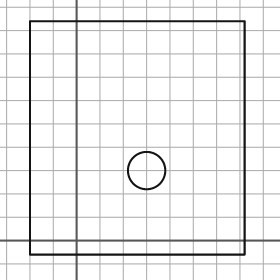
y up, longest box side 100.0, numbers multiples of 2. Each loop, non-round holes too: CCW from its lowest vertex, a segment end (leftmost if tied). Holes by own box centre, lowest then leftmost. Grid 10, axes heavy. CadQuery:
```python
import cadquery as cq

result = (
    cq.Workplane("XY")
    .moveTo(-20.0, -6.0)
    .lineTo(72.0, -6.0)
    .lineTo(72.0, 94.0)
    .lineTo(-20.0, 94.0)
    .close()
    .moveTo(30.0, 30.0)
    .circle(8.0)
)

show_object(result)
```